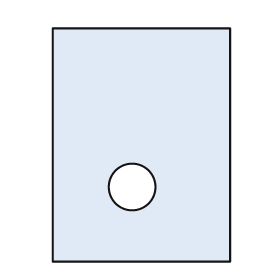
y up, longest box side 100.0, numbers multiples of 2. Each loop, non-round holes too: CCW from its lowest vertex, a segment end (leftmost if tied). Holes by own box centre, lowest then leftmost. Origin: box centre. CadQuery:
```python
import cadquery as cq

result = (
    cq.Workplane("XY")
    .moveTo(-38.0, -50.0)
    .lineTo(38.0, -50.0)
    .lineTo(38.0, 50.0)
    .lineTo(-38.0, 50.0)
    .close()
    .moveTo(-4.0, -18.0)
    .circle(10.0)
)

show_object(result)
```